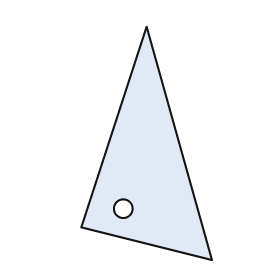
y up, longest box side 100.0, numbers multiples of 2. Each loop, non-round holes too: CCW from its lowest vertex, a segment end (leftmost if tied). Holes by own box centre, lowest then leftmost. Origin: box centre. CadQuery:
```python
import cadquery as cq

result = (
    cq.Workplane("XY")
    .moveTo(28.0, -50.0)
    .lineTo(0.0, 50.0)
    .lineTo(-28.0, -36.0)
    .close()
    .moveTo(-10.0, -28.0)
    .circle(4.0)
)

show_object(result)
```